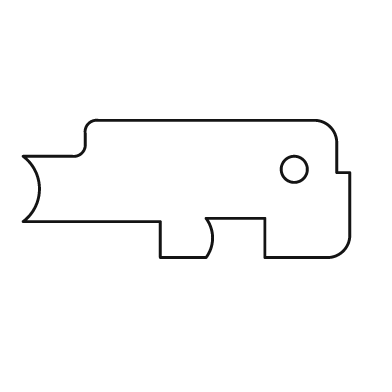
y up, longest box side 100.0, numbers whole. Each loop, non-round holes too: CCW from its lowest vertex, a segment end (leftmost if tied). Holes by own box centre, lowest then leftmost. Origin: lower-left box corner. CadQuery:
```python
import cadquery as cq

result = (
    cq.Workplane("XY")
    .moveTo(42.0, 0.0)
    .lineTo(56.0, 0.0)
    .threePointArc((58.0, 6.0), (56.0, 12.0))
    .lineTo(74.0, 12.0)
    .lineTo(74.0, 0.0)
    .lineTo(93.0, 0.0)
    .threePointArc((98.0, 2.0), (100.0, 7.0))
    .lineTo(100.0, 26.0)
    .lineTo(96.0, 26.0)
    .lineTo(96.0, 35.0)
    .threePointArc((94.0, 40.0), (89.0, 42.0))
    .lineTo(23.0, 42.0)
    .threePointArc((20.0, 41.0), (19.0, 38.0))
    .lineTo(19.0, 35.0)
    .threePointArc((18.0, 32.0), (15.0, 31.0))
    .lineTo(0.0, 31.0)
    .threePointArc((5.0, 21.0), (0.0, 11.0))
    .lineTo(42.0, 11.0)
    .close()
    .moveTo(83.0, 27.0)
    .circle(4.0)
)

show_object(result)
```